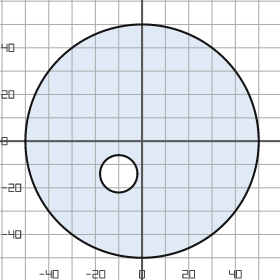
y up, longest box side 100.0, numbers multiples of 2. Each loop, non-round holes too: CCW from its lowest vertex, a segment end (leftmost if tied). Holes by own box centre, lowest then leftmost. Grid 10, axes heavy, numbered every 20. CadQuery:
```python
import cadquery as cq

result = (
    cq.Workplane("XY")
    .moveTo(0.0, 0.0)
    .circle(50.0)
    .moveTo(-10.0, -14.0)
    .circle(8.0)
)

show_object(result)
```